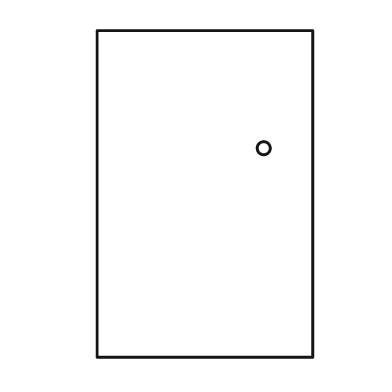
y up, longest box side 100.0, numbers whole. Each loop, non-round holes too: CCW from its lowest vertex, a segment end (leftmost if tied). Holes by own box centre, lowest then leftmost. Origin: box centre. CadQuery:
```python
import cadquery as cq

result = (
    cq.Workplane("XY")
    .moveTo(-33.0, -50.0)
    .lineTo(33.0, -50.0)
    .lineTo(33.0, 50.0)
    .lineTo(-33.0, 50.0)
    .close()
    .moveTo(18.0, 14.0)
    .circle(2.0)
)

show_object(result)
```